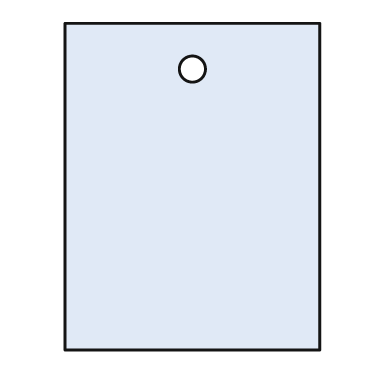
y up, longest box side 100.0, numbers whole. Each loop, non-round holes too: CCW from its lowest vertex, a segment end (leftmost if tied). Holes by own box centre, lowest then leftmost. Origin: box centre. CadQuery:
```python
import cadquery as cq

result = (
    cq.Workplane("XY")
    .moveTo(-39.0, -50.0)
    .lineTo(39.0, -50.0)
    .lineTo(39.0, 50.0)
    .lineTo(-39.0, 50.0)
    .close()
    .moveTo(0.0, 36.0)
    .circle(4.0)
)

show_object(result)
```